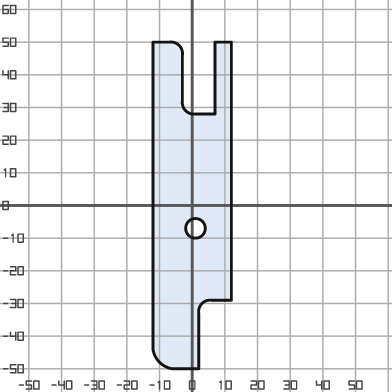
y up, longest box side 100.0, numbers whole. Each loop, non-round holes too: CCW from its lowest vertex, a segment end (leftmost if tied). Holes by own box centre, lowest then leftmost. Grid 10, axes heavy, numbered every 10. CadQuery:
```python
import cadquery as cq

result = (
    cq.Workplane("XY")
    .moveTo(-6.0, -50.0)
    .lineTo(2.0, -50.0)
    .lineTo(2.0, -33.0)
    .threePointArc((3.0, -30.0), (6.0, -29.0))
    .lineTo(12.0, -29.0)
    .lineTo(12.0, 50.0)
    .lineTo(7.0, 50.0)
    .lineTo(7.0, 28.0)
    .lineTo(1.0, 28.0)
    .threePointArc((-2.0, 29.0), (-3.0, 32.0))
    .lineTo(-3.0, 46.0)
    .threePointArc((-4.0, 49.0), (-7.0, 50.0))
    .lineTo(-12.0, 50.0)
    .lineTo(-12.0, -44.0)
    .threePointArc((-10.0, -48.0), (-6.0, -50.0))
    .close()
    .moveTo(1.0, -7.0)
    .circle(3.0)
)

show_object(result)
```